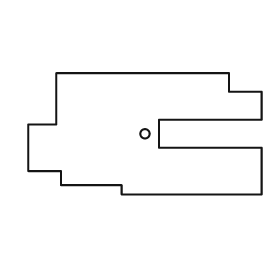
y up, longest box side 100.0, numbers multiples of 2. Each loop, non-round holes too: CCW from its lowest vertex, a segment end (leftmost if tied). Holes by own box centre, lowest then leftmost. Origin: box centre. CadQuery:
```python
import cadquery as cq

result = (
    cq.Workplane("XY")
    .moveTo(-10.0, -26.0)
    .lineTo(50.0, -26.0)
    .lineTo(50.0, -6.0)
    .lineTo(6.0, -6.0)
    .lineTo(6.0, 6.0)
    .lineTo(50.0, 6.0)
    .lineTo(50.0, 18.0)
    .lineTo(36.0, 18.0)
    .lineTo(36.0, 26.0)
    .lineTo(-38.0, 26.0)
    .lineTo(-38.0, 4.0)
    .lineTo(-50.0, 4.0)
    .lineTo(-50.0, -16.0)
    .lineTo(-36.0, -16.0)
    .lineTo(-36.0, -22.0)
    .lineTo(-10.0, -22.0)
    .close()
    .moveTo(0.0, 0.0)
    .circle(2.0)
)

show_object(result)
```